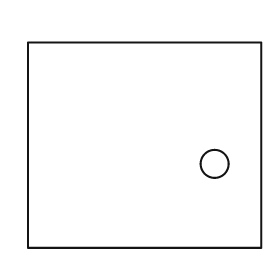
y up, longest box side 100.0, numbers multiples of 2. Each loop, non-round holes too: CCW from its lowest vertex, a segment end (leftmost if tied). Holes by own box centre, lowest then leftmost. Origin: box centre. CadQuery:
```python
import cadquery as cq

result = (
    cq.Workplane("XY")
    .moveTo(-50.0, -44.0)
    .lineTo(50.0, -44.0)
    .lineTo(50.0, 44.0)
    .lineTo(-50.0, 44.0)
    .close()
    .moveTo(30.0, -8.0)
    .circle(6.0)
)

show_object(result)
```